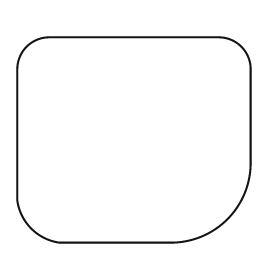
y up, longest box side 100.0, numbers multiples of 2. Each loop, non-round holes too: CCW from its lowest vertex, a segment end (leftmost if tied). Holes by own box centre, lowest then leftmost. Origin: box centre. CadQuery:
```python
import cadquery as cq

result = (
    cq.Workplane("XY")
    .moveTo(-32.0, -44.0)
    .lineTo(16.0, -44.0)
    .threePointArc((40.0, -34.0), (50.0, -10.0))
    .lineTo(50.0, 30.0)
    .threePointArc((46.0, 40.0), (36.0, 44.0))
    .lineTo(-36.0, 44.0)
    .threePointArc((-46.0, 40.0), (-50.0, 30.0))
    .lineTo(-50.0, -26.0)
    .threePointArc((-44.0, -38.0), (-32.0, -44.0))
    .close()
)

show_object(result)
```